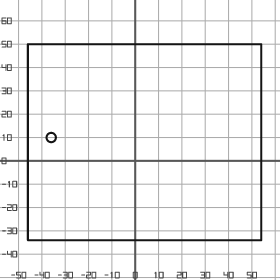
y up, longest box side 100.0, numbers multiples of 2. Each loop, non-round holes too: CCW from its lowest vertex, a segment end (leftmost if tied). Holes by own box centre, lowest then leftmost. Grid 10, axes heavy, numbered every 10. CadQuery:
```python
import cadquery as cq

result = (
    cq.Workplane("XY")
    .moveTo(-46.0, -34.0)
    .lineTo(54.0, -34.0)
    .lineTo(54.0, 50.0)
    .lineTo(-46.0, 50.0)
    .close()
    .moveTo(-36.0, 10.0)
    .circle(2.0)
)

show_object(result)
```